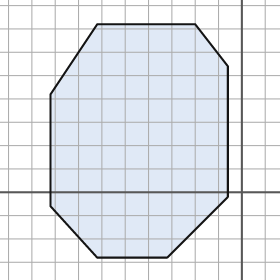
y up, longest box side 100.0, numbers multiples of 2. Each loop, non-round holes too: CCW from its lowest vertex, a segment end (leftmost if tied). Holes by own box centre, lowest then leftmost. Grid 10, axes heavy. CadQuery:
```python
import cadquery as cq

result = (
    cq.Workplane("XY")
    .moveTo(-62.0, -28.0)
    .lineTo(-32.0, -28.0)
    .lineTo(-6.0, -2.0)
    .lineTo(-6.0, 54.0)
    .lineTo(-20.0, 72.0)
    .lineTo(-62.0, 72.0)
    .lineTo(-82.0, 42.0)
    .lineTo(-82.0, -6.0)
    .close()
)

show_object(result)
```